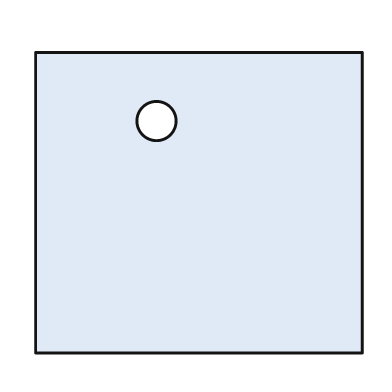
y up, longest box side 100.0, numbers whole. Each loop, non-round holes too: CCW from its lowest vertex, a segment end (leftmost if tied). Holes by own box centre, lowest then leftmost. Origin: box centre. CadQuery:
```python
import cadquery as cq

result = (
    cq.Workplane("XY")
    .moveTo(-50.0, -46.0)
    .lineTo(50.0, -46.0)
    .lineTo(50.0, 46.0)
    .lineTo(-50.0, 46.0)
    .close()
    .moveTo(-13.0, 25.0)
    .circle(6.0)
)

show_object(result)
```